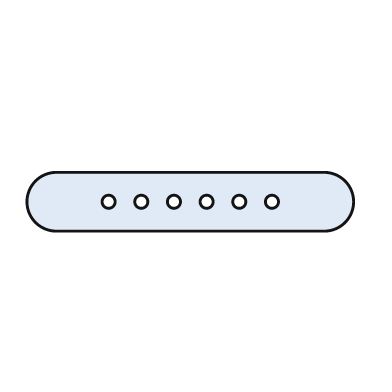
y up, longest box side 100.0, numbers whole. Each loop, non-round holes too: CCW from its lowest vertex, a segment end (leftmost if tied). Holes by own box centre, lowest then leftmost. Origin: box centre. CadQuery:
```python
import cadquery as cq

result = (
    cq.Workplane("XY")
    .moveTo(-41.0, -9.0)
    .lineTo(41.0, -9.0)
    .threePointArc((50.0, 0.0), (41.0, 9.0))
    .lineTo(-41.0, 9.0)
    .threePointArc((-50.0, 0.0), (-41.0, -9.0))
    .close()
    .moveTo(-25.0, 0.0)
    .circle(2.0)
    .moveTo(-15.0, 0.0)
    .circle(2.0)
    .moveTo(-5.0, 0.0)
    .circle(2.0)
    .moveTo(5.0, 0.0)
    .circle(2.0)
    .moveTo(15.0, 0.0)
    .circle(2.0)
    .moveTo(25.0, 0.0)
    .circle(2.0)
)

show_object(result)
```